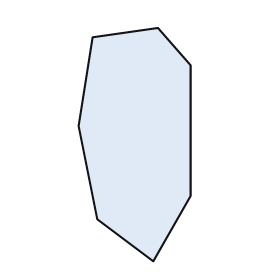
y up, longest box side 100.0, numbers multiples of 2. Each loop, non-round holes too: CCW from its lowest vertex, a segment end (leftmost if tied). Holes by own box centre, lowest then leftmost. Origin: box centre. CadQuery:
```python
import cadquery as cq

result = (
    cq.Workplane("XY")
    .moveTo(8.0, -50.0)
    .lineTo(24.0, -22.0)
    .lineTo(24.0, 34.0)
    .lineTo(10.0, 50.0)
    .lineTo(-18.0, 46.0)
    .lineTo(-24.0, 8.0)
    .lineTo(-16.0, -32.0)
    .close()
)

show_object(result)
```